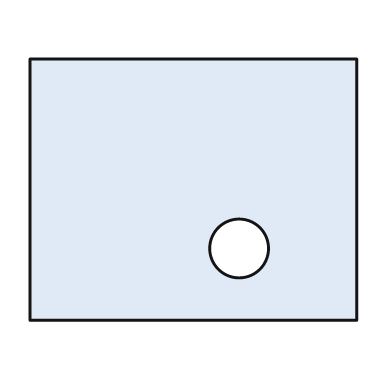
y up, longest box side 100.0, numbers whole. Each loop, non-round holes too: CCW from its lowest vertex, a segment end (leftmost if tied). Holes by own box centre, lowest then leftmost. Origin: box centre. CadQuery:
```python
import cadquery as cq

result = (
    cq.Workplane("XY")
    .moveTo(-50.0, -40.0)
    .lineTo(50.0, -40.0)
    .lineTo(50.0, 40.0)
    .lineTo(-50.0, 40.0)
    .close()
    .moveTo(14.0, -18.0)
    .circle(9.0)
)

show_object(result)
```